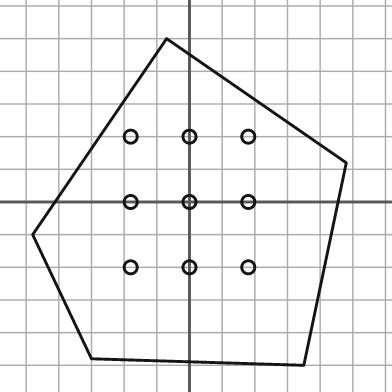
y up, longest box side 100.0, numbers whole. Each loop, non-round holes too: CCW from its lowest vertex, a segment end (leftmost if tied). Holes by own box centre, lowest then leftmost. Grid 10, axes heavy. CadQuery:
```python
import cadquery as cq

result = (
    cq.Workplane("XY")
    .moveTo(35.0, -50.0)
    .lineTo(48.0, 12.0)
    .lineTo(-7.0, 50.0)
    .lineTo(-48.0, -10.0)
    .lineTo(-30.0, -48.0)
    .close()
    .moveTo(-18.0, -20.0)
    .circle(2.0)
    .moveTo(0.0, -20.0)
    .circle(2.0)
    .moveTo(18.0, -20.0)
    .circle(2.0)
    .moveTo(-18.0, 0.0)
    .circle(2.0)
    .moveTo(0.0, 0.0)
    .circle(2.0)
    .moveTo(18.0, 0.0)
    .circle(2.0)
    .moveTo(-18.0, 20.0)
    .circle(2.0)
    .moveTo(0.0, 20.0)
    .circle(2.0)
    .moveTo(18.0, 20.0)
    .circle(2.0)
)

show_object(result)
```